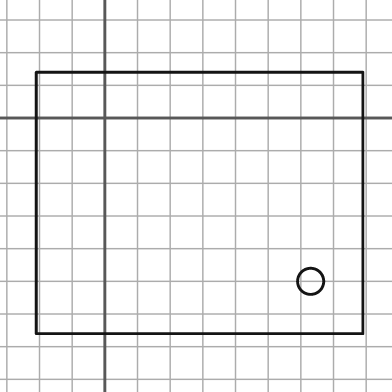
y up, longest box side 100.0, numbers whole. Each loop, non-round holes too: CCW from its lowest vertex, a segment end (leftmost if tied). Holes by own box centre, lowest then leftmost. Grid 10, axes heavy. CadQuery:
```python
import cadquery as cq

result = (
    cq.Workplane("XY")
    .moveTo(-21.0, -66.0)
    .lineTo(79.0, -66.0)
    .lineTo(79.0, 14.0)
    .lineTo(-21.0, 14.0)
    .close()
    .moveTo(63.0, -50.0)
    .circle(4.0)
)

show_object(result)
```